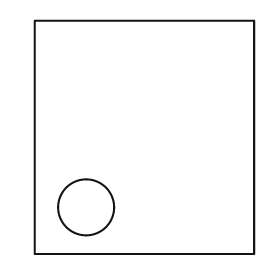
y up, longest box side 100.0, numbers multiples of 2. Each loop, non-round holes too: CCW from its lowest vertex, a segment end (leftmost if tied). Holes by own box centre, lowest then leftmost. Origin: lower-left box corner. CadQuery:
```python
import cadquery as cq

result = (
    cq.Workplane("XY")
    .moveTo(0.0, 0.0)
    .lineTo(94.0, 0.0)
    .lineTo(94.0, 100.0)
    .lineTo(0.0, 100.0)
    .close()
    .moveTo(22.0, 20.0)
    .circle(12.0)
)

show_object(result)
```